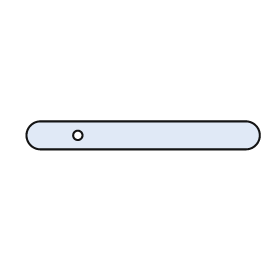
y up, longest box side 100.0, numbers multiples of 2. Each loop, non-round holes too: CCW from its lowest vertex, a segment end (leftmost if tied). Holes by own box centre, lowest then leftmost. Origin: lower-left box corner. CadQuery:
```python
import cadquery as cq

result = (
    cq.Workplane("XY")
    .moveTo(6.0, 0.0)
    .lineTo(94.0, 0.0)
    .threePointArc((100.0, 6.0), (94.0, 12.0))
    .lineTo(6.0, 12.0)
    .threePointArc((0.0, 6.0), (6.0, 0.0))
    .close()
    .moveTo(22.0, 6.0)
    .circle(2.0)
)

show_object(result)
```